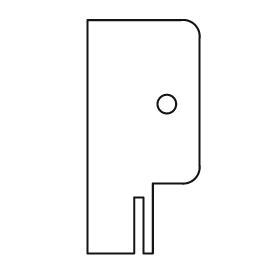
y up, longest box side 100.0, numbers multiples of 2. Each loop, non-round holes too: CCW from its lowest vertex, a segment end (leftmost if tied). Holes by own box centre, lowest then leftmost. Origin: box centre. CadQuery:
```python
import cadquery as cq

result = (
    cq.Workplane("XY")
    .moveTo(-24.0, -50.0)
    .lineTo(-4.0, -50.0)
    .lineTo(-4.0, -26.0)
    .lineTo(0.0, -26.0)
    .lineTo(0.0, -50.0)
    .lineTo(4.0, -50.0)
    .lineTo(4.0, -20.0)
    .lineTo(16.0, -20.0)
    .threePointArc((22.0, -18.0), (24.0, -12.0))
    .lineTo(24.0, 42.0)
    .threePointArc((22.0, 48.0), (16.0, 50.0))
    .lineTo(-24.0, 50.0)
    .close()
    .moveTo(10.0, 14.0)
    .circle(4.0)
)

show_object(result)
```